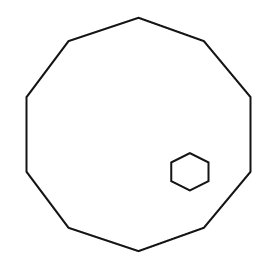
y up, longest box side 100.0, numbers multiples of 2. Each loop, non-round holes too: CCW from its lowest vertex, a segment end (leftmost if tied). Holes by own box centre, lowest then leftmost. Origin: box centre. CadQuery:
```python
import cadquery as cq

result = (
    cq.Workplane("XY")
    .moveTo(0.0, -50.0)
    .lineTo(28.0, -40.0)
    .lineTo(48.0, -16.0)
    .lineTo(48.0, 16.0)
    .lineTo(28.0, 40.0)
    .lineTo(0.0, 50.0)
    .lineTo(-30.0, 40.0)
    .lineTo(-48.0, 16.0)
    .lineTo(-48.0, -16.0)
    .lineTo(-30.0, -40.0)
    .close()
    .moveTo(22.0, -24.0)
    .lineTo(30.0, -20.0)
    .lineTo(30.0, -12.0)
    .lineTo(22.0, -8.0)
    .lineTo(14.0, -12.0)
    .lineTo(14.0, -20.0)
    .close()
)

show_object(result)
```